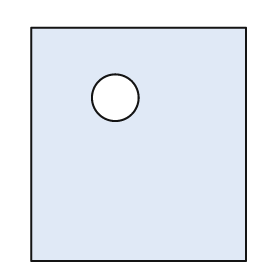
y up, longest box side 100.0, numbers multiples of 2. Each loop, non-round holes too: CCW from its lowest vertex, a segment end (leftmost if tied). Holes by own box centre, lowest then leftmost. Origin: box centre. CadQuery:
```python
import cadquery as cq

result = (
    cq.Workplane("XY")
    .moveTo(-46.0, -50.0)
    .lineTo(46.0, -50.0)
    .lineTo(46.0, 50.0)
    .lineTo(-46.0, 50.0)
    .close()
    .moveTo(-10.0, 20.0)
    .circle(10.0)
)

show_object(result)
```